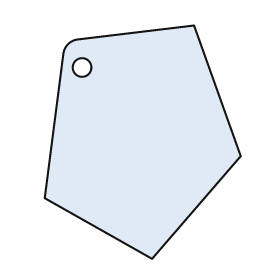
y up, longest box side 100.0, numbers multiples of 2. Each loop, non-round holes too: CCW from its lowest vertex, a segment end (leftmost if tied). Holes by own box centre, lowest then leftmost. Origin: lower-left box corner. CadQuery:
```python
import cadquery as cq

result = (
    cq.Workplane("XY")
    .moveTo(46.0, 0.0)
    .lineTo(84.0, 44.0)
    .lineTo(64.0, 100.0)
    .lineTo(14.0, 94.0)
    .threePointArc((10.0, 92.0), (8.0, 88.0))
    .lineTo(0.0, 26.0)
    .close()
    .moveTo(16.0, 82.0)
    .circle(4.0)
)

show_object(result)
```